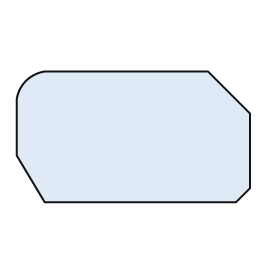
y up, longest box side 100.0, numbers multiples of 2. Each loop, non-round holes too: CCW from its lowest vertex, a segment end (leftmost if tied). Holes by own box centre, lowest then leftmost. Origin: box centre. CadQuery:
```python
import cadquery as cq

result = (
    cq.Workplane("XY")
    .moveTo(-38.0, -28.0)
    .lineTo(44.0, -28.0)
    .lineTo(50.0, -22.0)
    .lineTo(50.0, 10.0)
    .lineTo(32.0, 28.0)
    .lineTo(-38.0, 28.0)
    .threePointArc((-46.0, 24.0), (-50.0, 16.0))
    .lineTo(-50.0, -8.0)
    .close()
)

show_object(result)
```